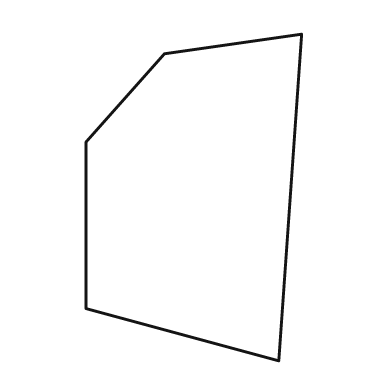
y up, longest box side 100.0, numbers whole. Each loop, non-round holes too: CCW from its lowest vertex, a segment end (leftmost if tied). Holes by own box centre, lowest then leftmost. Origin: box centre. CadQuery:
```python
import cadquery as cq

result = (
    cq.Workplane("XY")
    .moveTo(26.0, -50.0)
    .lineTo(33.0, 50.0)
    .lineTo(-9.0, 44.0)
    .lineTo(-33.0, 17.0)
    .lineTo(-33.0, -34.0)
    .close()
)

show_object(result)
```